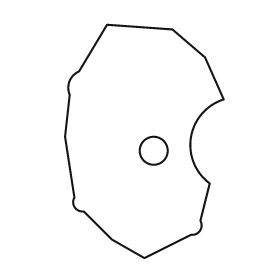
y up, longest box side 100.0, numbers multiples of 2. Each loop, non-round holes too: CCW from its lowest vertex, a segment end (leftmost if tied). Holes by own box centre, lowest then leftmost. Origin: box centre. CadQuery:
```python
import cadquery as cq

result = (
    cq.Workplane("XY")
    .moveTo(0.0, -50.0)
    .lineTo(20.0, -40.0)
    .threePointArc((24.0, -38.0), (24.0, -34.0))
    .lineTo(28.0, -18.0)
    .threePointArc((20.0, 2.0), (34.0, 18.0))
    .lineTo(26.0, 36.0)
    .lineTo(12.0, 48.0)
    .lineTo(-16.0, 50.0)
    .lineTo(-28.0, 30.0)
    .threePointArc((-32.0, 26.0), (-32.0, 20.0))
    .lineTo(-34.0, 2.0)
    .lineTo(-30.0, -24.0)
    .threePointArc((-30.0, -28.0), (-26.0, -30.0))
    .lineTo(-14.0, -42.0)
    .close()
    .moveTo(4.0, -4.0)
    .circle(6.0)
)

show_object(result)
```